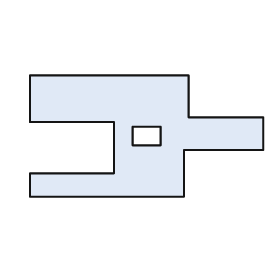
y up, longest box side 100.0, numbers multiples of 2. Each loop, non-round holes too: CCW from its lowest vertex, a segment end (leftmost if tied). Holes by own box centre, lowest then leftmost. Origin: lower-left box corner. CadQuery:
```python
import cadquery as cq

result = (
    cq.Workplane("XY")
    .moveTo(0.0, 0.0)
    .lineTo(66.0, 0.0)
    .lineTo(66.0, 20.0)
    .lineTo(100.0, 20.0)
    .lineTo(100.0, 34.0)
    .lineTo(68.0, 34.0)
    .lineTo(68.0, 52.0)
    .lineTo(0.0, 52.0)
    .lineTo(0.0, 32.0)
    .lineTo(36.0, 32.0)
    .lineTo(36.0, 10.0)
    .lineTo(0.0, 10.0)
    .close()
    .moveTo(44.0, 22.0)
    .lineTo(56.0, 22.0)
    .lineTo(56.0, 30.0)
    .lineTo(44.0, 30.0)
    .close()
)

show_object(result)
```